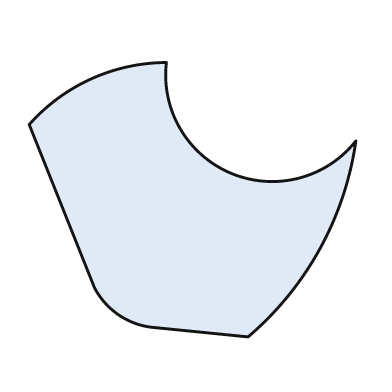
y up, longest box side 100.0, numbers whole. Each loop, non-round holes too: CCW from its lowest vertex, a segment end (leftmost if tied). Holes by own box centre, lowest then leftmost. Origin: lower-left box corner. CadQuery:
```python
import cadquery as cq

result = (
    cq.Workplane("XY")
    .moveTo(67.0, 0.0)
    .threePointArc((89.0, 27.0), (100.0, 60.0))
    .threePointArc((62.0, 50.0), (42.0, 84.0))
    .threePointArc((19.0, 79.0), (0.0, 65.0))
    .lineTo(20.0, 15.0)
    .threePointArc((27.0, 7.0), (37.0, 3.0))
    .close()
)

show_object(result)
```